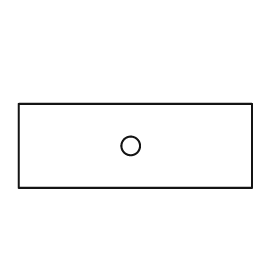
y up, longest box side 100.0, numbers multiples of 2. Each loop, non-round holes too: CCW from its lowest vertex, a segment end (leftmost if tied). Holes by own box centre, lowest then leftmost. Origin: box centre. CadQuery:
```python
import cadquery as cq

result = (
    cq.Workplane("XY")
    .moveTo(-50.0, -18.0)
    .lineTo(50.0, -18.0)
    .lineTo(50.0, 18.0)
    .lineTo(-50.0, 18.0)
    .close()
    .moveTo(-2.0, 0.0)
    .circle(4.0)
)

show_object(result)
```